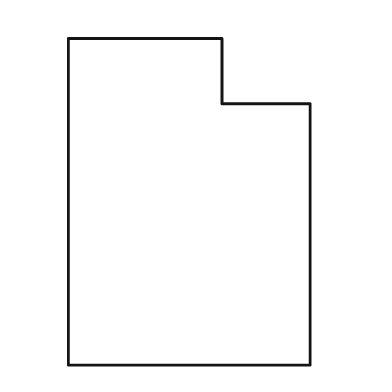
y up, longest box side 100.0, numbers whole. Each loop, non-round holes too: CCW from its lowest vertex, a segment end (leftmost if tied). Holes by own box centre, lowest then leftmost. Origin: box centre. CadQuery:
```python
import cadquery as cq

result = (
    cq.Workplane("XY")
    .moveTo(-37.0, -50.0)
    .lineTo(37.0, -50.0)
    .lineTo(37.0, 30.0)
    .lineTo(10.0, 30.0)
    .lineTo(10.0, 50.0)
    .lineTo(-37.0, 50.0)
    .close()
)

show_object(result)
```